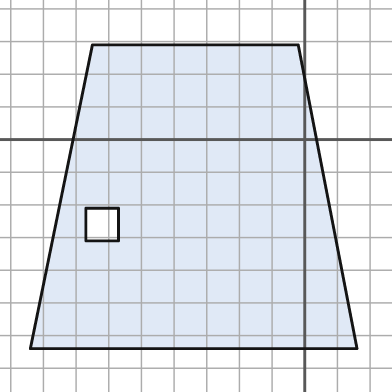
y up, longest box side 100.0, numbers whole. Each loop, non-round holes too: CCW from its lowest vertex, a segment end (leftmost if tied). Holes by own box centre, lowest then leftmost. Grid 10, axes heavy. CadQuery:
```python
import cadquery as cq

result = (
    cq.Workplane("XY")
    .moveTo(-84.0, -64.0)
    .lineTo(16.0, -64.0)
    .lineTo(-2.0, 29.0)
    .lineTo(-65.0, 29.0)
    .close()
    .moveTo(-67.0, -31.0)
    .lineTo(-57.0, -31.0)
    .lineTo(-57.0, -21.0)
    .lineTo(-67.0, -21.0)
    .close()
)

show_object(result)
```